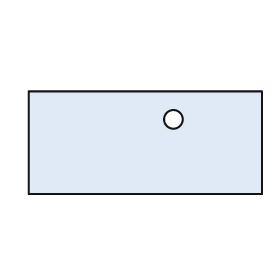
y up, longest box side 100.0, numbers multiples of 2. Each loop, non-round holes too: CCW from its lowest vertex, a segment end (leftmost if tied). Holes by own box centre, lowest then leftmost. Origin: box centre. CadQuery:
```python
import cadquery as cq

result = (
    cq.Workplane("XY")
    .moveTo(-50.0, -22.0)
    .lineTo(50.0, -22.0)
    .lineTo(50.0, 22.0)
    .lineTo(-50.0, 22.0)
    .close()
    .moveTo(12.0, 10.0)
    .circle(4.0)
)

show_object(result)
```